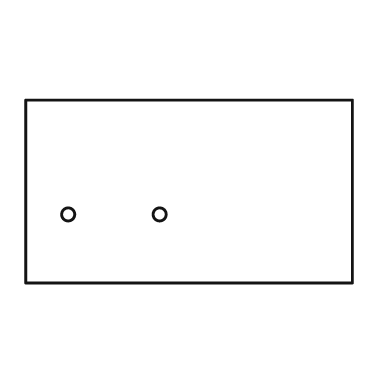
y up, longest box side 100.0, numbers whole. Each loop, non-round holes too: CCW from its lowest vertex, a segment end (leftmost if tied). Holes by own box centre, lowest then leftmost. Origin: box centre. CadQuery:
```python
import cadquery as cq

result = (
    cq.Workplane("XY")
    .moveTo(-50.0, -28.0)
    .lineTo(50.0, -28.0)
    .lineTo(50.0, 28.0)
    .lineTo(-50.0, 28.0)
    .close()
    .moveTo(-37.0, -7.0)
    .circle(2.0)
    .moveTo(-9.0, -7.0)
    .circle(2.0)
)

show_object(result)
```